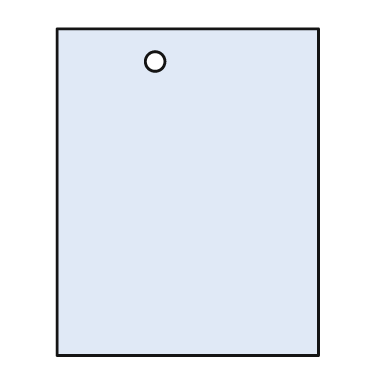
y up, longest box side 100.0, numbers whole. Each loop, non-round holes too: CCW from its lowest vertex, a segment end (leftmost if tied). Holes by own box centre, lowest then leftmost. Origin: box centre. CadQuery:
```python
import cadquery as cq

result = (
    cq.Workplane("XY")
    .moveTo(-40.0, -50.0)
    .lineTo(40.0, -50.0)
    .lineTo(40.0, 50.0)
    .lineTo(-40.0, 50.0)
    .close()
    .moveTo(-10.0, 40.0)
    .circle(3.0)
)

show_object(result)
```